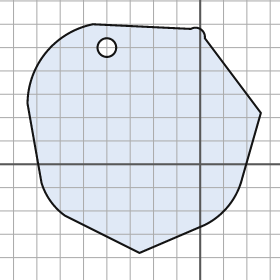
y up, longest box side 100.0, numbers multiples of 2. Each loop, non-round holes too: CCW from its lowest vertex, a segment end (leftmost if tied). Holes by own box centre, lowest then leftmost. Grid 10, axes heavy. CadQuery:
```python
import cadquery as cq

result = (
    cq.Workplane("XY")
    .moveTo(-26.0, -38.0)
    .lineTo(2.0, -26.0)
    .threePointArc((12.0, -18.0), (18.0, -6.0))
    .lineTo(26.0, 22.0)
    .lineTo(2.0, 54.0)
    .threePointArc((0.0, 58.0), (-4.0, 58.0))
    .lineTo(-46.0, 60.0)
    .threePointArc((-66.0, 48.0), (-74.0, 26.0))
    .lineTo(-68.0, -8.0)
    .threePointArc((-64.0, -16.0), (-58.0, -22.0))
    .close()
    .moveTo(-40.0, 50.0)
    .circle(4.0)
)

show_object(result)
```